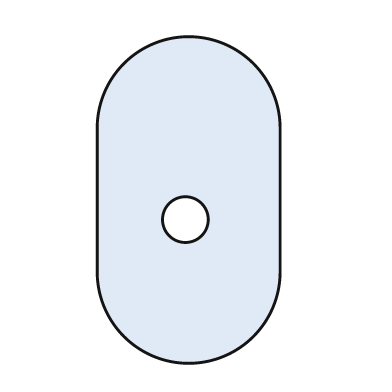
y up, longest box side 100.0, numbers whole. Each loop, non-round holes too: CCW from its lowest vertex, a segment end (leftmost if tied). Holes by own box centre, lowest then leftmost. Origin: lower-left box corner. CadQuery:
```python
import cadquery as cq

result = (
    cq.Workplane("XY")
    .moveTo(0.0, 28.0)
    .threePointArc((28.0, 0.0), (56.0, 28.0))
    .lineTo(56.0, 72.0)
    .threePointArc((28.0, 100.0), (0.0, 72.0))
    .close()
    .moveTo(27.0, 44.0)
    .circle(7.0)
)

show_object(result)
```